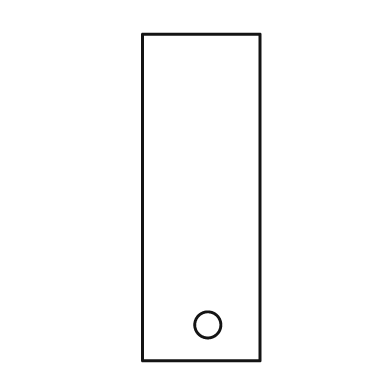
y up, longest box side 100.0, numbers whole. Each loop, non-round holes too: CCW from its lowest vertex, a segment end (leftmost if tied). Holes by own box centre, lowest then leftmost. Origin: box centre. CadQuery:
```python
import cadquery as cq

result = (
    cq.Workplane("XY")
    .moveTo(-18.0, -50.0)
    .lineTo(18.0, -50.0)
    .lineTo(18.0, 50.0)
    .lineTo(-18.0, 50.0)
    .close()
    .moveTo(2.0, -39.0)
    .circle(4.0)
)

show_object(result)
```